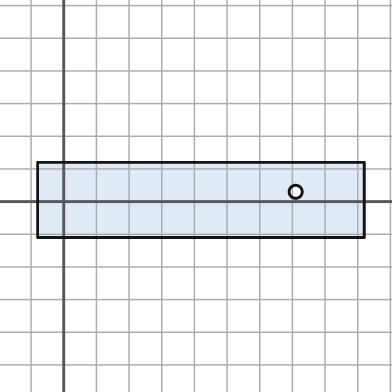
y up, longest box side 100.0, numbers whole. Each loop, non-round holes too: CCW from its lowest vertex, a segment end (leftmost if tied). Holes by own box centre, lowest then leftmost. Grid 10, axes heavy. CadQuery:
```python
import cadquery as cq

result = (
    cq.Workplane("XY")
    .moveTo(-8.0, -11.0)
    .lineTo(92.0, -11.0)
    .lineTo(92.0, 12.0)
    .lineTo(-8.0, 12.0)
    .close()
    .moveTo(71.0, 3.0)
    .circle(2.0)
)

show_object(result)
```